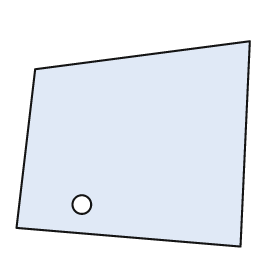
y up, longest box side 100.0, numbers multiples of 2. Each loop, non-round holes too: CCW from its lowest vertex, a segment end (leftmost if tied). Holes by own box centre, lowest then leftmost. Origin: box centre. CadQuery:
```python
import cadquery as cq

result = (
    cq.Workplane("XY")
    .moveTo(46.0, -44.0)
    .lineTo(50.0, 44.0)
    .lineTo(-42.0, 32.0)
    .lineTo(-50.0, -36.0)
    .close()
    .moveTo(-22.0, -26.0)
    .circle(4.0)
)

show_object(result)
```